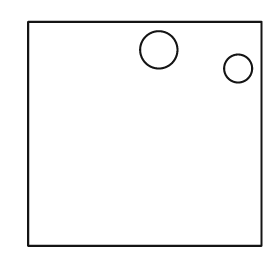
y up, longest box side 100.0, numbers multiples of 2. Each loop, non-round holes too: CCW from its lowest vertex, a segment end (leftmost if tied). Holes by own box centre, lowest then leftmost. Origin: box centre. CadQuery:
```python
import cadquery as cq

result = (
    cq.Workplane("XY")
    .moveTo(-50.0, -48.0)
    .lineTo(50.0, -48.0)
    .lineTo(50.0, 48.0)
    .lineTo(-50.0, 48.0)
    .close()
    .moveTo(40.0, 28.0)
    .circle(6.0)
    .moveTo(6.0, 36.0)
    .circle(8.0)
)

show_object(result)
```